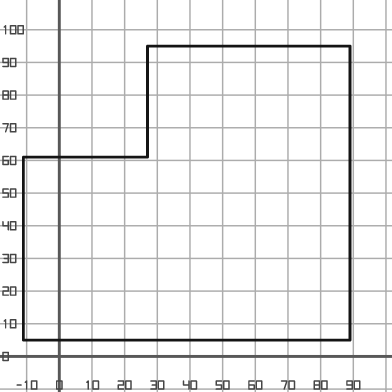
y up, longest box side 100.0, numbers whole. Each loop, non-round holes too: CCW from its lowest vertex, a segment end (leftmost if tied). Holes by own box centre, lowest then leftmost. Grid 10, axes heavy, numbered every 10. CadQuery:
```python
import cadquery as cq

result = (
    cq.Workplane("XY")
    .moveTo(-11.0, 5.0)
    .lineTo(89.0, 5.0)
    .lineTo(89.0, 95.0)
    .lineTo(27.0, 95.0)
    .lineTo(27.0, 61.0)
    .lineTo(-11.0, 61.0)
    .close()
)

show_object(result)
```